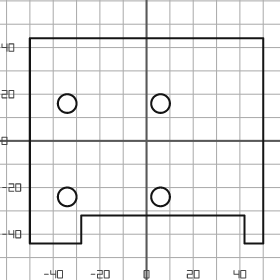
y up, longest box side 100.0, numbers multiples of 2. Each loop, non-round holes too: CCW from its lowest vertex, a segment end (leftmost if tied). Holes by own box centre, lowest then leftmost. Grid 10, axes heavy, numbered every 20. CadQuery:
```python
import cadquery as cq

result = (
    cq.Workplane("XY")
    .moveTo(-50.0, -44.0)
    .lineTo(-28.0, -44.0)
    .lineTo(-28.0, -32.0)
    .lineTo(42.0, -32.0)
    .lineTo(42.0, -44.0)
    .lineTo(50.0, -44.0)
    .lineTo(50.0, 44.0)
    .lineTo(-50.0, 44.0)
    .close()
    .moveTo(-34.0, -24.0)
    .circle(4.0)
    .moveTo(6.0, -24.0)
    .circle(4.0)
    .moveTo(-34.0, 16.0)
    .circle(4.0)
    .moveTo(6.0, 16.0)
    .circle(4.0)
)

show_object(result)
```